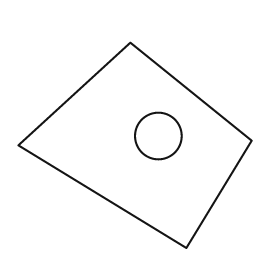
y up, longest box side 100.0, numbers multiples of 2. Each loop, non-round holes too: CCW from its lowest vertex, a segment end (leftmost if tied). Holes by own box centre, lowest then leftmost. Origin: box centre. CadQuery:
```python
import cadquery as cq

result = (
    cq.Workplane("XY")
    .moveTo(22.0, -44.0)
    .lineTo(50.0, 2.0)
    .lineTo(-2.0, 44.0)
    .lineTo(-50.0, 0.0)
    .close()
    .moveTo(10.0, 4.0)
    .circle(10.0)
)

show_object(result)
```